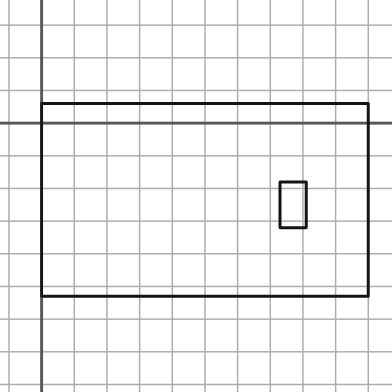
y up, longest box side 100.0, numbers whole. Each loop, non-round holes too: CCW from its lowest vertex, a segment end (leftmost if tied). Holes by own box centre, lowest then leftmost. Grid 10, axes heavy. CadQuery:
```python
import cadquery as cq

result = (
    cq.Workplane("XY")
    .moveTo(0.0, -53.0)
    .lineTo(100.0, -53.0)
    .lineTo(100.0, 6.0)
    .lineTo(0.0, 6.0)
    .close()
    .moveTo(73.0, -32.0)
    .lineTo(81.0, -32.0)
    .lineTo(81.0, -18.0)
    .lineTo(73.0, -18.0)
    .close()
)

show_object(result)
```